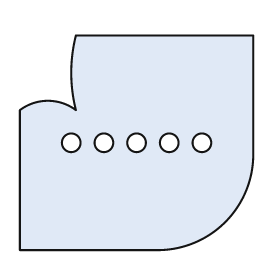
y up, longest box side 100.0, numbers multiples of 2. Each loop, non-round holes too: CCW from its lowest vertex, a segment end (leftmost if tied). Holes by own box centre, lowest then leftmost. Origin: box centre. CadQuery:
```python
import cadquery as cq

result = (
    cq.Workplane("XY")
    .moveTo(-50.0, -46.0)
    .lineTo(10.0, -46.0)
    .threePointArc((38.0, -34.0), (50.0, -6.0))
    .lineTo(50.0, 46.0)
    .lineTo(-26.0, 46.0)
    .threePointArc((-28.0, 30.0), (-26.0, 14.0))
    .threePointArc((-38.0, 18.0), (-50.0, 14.0))
    .close()
    .moveTo(-28.0, 0.0)
    .circle(4.0)
    .moveTo(-14.0, 0.0)
    .circle(4.0)
    .moveTo(0.0, 0.0)
    .circle(4.0)
    .moveTo(14.0, 0.0)
    .circle(4.0)
    .moveTo(28.0, 0.0)
    .circle(4.0)
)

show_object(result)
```